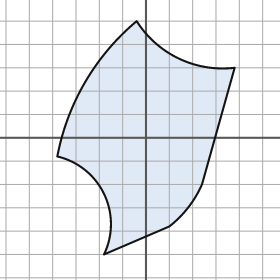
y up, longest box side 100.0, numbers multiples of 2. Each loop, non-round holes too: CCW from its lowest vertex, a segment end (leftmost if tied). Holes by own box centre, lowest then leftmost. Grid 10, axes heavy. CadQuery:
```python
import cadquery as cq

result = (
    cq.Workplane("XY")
    .moveTo(-18.0, -50.0)
    .lineTo(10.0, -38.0)
    .threePointArc((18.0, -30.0), (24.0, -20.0))
    .lineTo(38.0, 30.0)
    .threePointArc((14.0, 34.0), (-4.0, 50.0))
    .threePointArc((-26.0, 24.0), (-38.0, -8.0))
    .threePointArc((-18.0, -24.0), (-18.0, -50.0))
    .close()
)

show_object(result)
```